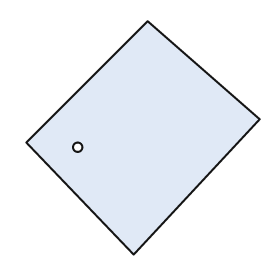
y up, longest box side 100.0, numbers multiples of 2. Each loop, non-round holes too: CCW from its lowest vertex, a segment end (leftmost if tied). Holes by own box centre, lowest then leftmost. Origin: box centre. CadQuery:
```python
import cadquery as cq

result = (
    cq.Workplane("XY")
    .moveTo(-4.0, -50.0)
    .lineTo(50.0, 8.0)
    .lineTo(2.0, 50.0)
    .lineTo(-50.0, -2.0)
    .close()
    .moveTo(-28.0, -4.0)
    .circle(2.0)
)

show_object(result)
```